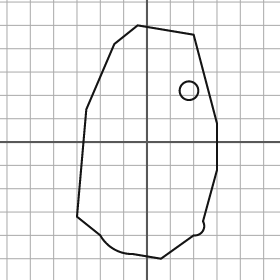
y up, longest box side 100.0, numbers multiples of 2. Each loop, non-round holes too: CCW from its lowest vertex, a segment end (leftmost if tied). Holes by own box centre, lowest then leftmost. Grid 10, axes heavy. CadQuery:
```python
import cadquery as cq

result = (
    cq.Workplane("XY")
    .moveTo(6.0, -50.0)
    .lineTo(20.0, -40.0)
    .threePointArc((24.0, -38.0), (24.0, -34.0))
    .lineTo(30.0, -12.0)
    .lineTo(30.0, 8.0)
    .lineTo(20.0, 46.0)
    .lineTo(-4.0, 50.0)
    .lineTo(-14.0, 42.0)
    .lineTo(-26.0, 14.0)
    .lineTo(-30.0, -32.0)
    .lineTo(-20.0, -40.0)
    .threePointArc((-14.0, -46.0), (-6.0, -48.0))
    .close()
    .moveTo(18.0, 22.0)
    .circle(4.0)
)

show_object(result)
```